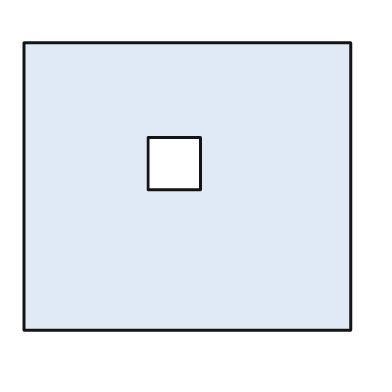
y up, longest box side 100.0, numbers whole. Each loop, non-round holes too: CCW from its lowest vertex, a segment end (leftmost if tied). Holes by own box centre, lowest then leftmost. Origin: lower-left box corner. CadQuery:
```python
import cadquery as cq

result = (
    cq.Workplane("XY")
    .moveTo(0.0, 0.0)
    .lineTo(100.0, 0.0)
    .lineTo(100.0, 88.0)
    .lineTo(0.0, 88.0)
    .close()
    .moveTo(38.0, 43.0)
    .lineTo(54.0, 43.0)
    .lineTo(54.0, 59.0)
    .lineTo(38.0, 59.0)
    .close()
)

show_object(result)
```